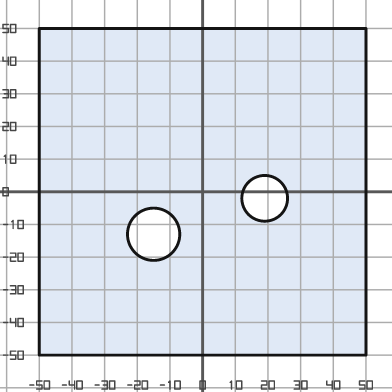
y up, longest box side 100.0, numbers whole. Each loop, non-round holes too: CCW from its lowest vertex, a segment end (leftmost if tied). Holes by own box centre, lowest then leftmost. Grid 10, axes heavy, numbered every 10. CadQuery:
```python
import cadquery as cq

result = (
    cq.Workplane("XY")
    .moveTo(-50.0, -50.0)
    .lineTo(50.0, -50.0)
    .lineTo(50.0, 50.0)
    .lineTo(-50.0, 50.0)
    .close()
    .moveTo(-15.0, -13.0)
    .circle(8.0)
    .moveTo(19.0, -2.0)
    .circle(7.0)
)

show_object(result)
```